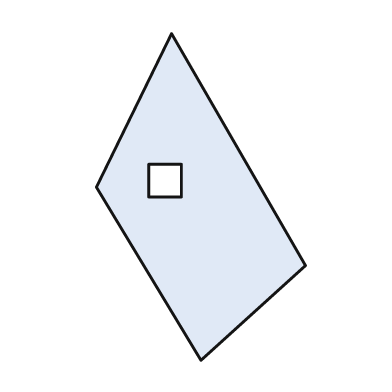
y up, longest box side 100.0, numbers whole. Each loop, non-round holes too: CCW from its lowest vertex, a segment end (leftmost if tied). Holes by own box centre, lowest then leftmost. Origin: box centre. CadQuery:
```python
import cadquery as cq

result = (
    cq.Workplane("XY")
    .moveTo(0.0, -50.0)
    .lineTo(32.0, -21.0)
    .lineTo(-9.0, 50.0)
    .lineTo(-32.0, 3.0)
    .close()
    .moveTo(-16.0, 0.0)
    .lineTo(-6.0, 0.0)
    .lineTo(-6.0, 10.0)
    .lineTo(-16.0, 10.0)
    .close()
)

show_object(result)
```